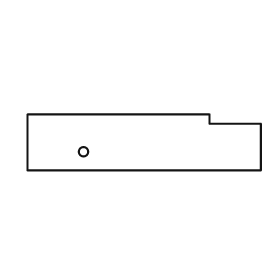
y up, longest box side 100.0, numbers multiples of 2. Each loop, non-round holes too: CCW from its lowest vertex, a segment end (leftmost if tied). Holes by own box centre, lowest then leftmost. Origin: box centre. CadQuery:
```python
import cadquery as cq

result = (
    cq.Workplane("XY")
    .moveTo(-50.0, -12.0)
    .lineTo(50.0, -12.0)
    .lineTo(50.0, 8.0)
    .lineTo(28.0, 8.0)
    .lineTo(28.0, 12.0)
    .lineTo(-50.0, 12.0)
    .close()
    .moveTo(-26.0, -4.0)
    .circle(2.0)
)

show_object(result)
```